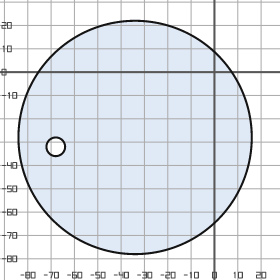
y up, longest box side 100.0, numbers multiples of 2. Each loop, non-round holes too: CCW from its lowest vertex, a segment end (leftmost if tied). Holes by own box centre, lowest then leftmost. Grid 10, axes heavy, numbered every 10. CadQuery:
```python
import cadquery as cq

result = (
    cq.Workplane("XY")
    .moveTo(-34.0, -28.0)
    .circle(50.0)
    .moveTo(-68.0, -32.0)
    .circle(4.0)
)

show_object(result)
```